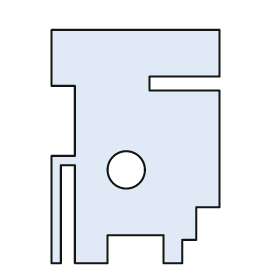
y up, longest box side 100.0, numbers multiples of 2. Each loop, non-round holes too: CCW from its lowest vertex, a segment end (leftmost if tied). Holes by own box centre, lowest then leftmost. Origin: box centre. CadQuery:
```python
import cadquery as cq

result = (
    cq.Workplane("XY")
    .moveTo(-36.0, -50.0)
    .lineTo(-32.0, -50.0)
    .lineTo(-32.0, -8.0)
    .lineTo(-26.0, -8.0)
    .lineTo(-26.0, -50.0)
    .lineTo(-12.0, -50.0)
    .lineTo(-12.0, -38.0)
    .lineTo(12.0, -38.0)
    .lineTo(12.0, -50.0)
    .lineTo(20.0, -50.0)
    .lineTo(20.0, -40.0)
    .lineTo(26.0, -40.0)
    .lineTo(26.0, -26.0)
    .lineTo(36.0, -26.0)
    .lineTo(36.0, 24.0)
    .lineTo(6.0, 24.0)
    .lineTo(6.0, 30.0)
    .lineTo(36.0, 30.0)
    .lineTo(36.0, 50.0)
    .lineTo(-36.0, 50.0)
    .lineTo(-36.0, 26.0)
    .lineTo(-26.0, 26.0)
    .lineTo(-26.0, -4.0)
    .lineTo(-36.0, -4.0)
    .close()
    .moveTo(-4.0, -10.0)
    .circle(8.0)
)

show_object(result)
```